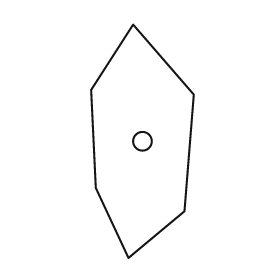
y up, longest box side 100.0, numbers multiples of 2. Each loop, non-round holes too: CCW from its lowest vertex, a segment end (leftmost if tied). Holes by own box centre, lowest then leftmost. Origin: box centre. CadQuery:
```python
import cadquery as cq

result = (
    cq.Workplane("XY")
    .moveTo(-6.0, -50.0)
    .lineTo(18.0, -30.0)
    .lineTo(22.0, 20.0)
    .lineTo(-4.0, 50.0)
    .lineTo(-22.0, 22.0)
    .lineTo(-20.0, -20.0)
    .close()
    .moveTo(0.0, 0.0)
    .circle(4.0)
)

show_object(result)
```